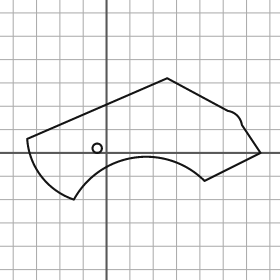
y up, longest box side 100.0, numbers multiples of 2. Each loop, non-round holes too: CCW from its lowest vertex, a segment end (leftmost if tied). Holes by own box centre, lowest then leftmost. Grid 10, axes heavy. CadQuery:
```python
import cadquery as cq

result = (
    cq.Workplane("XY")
    .moveTo(-14.0, -20.0)
    .threePointArc((12.0, -2.0), (42.0, -12.0))
    .lineTo(66.0, 0.0)
    .lineTo(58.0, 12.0)
    .threePointArc((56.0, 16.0), (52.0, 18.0))
    .lineTo(26.0, 32.0)
    .lineTo(-34.0, 6.0)
    .threePointArc((-28.0, -10.0), (-14.0, -20.0))
    .close()
    .moveTo(-4.0, 2.0)
    .circle(2.0)
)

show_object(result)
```